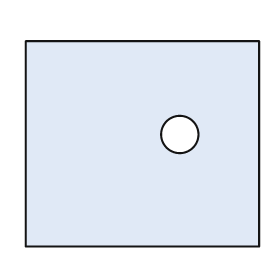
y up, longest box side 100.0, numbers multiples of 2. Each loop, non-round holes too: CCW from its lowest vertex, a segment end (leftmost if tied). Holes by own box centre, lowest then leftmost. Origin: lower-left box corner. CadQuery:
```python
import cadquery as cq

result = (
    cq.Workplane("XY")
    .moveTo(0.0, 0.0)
    .lineTo(100.0, 0.0)
    .lineTo(100.0, 88.0)
    .lineTo(0.0, 88.0)
    .close()
    .moveTo(66.0, 48.0)
    .circle(8.0)
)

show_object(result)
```